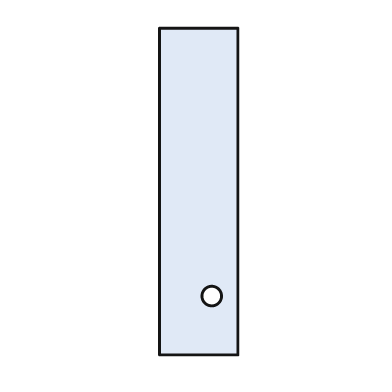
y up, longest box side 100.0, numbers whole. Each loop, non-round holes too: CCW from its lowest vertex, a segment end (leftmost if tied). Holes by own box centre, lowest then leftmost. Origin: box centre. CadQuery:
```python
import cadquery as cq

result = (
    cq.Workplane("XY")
    .moveTo(-12.0, -50.0)
    .lineTo(12.0, -50.0)
    .lineTo(12.0, 50.0)
    .lineTo(-12.0, 50.0)
    .close()
    .moveTo(4.0, -32.0)
    .circle(3.0)
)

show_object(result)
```